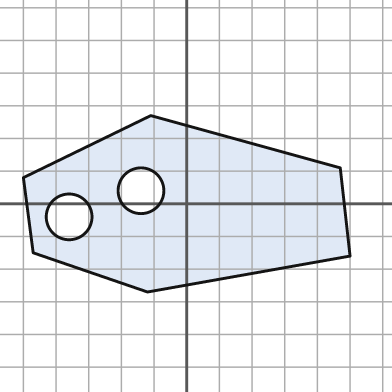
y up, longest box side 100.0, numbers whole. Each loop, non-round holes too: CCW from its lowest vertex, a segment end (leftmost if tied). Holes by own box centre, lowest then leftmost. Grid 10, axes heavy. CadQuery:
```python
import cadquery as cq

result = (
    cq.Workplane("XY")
    .moveTo(-12.0, -27.0)
    .lineTo(50.0, -16.0)
    .lineTo(47.0, 11.0)
    .lineTo(-11.0, 27.0)
    .lineTo(-50.0, 8.0)
    .lineTo(-47.0, -15.0)
    .close()
    .moveTo(-36.0, -4.0)
    .circle(7.0)
    .moveTo(-14.0, 4.0)
    .circle(7.0)
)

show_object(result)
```